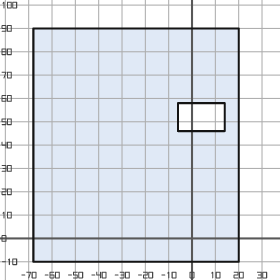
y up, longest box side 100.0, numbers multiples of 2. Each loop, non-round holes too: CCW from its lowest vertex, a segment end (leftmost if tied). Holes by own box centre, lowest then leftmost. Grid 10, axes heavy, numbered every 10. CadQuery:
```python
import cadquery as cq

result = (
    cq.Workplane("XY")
    .moveTo(-68.0, -10.0)
    .lineTo(20.0, -10.0)
    .lineTo(20.0, 90.0)
    .lineTo(-68.0, 90.0)
    .close()
    .moveTo(-6.0, 46.0)
    .lineTo(14.0, 46.0)
    .lineTo(14.0, 58.0)
    .lineTo(-6.0, 58.0)
    .close()
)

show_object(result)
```